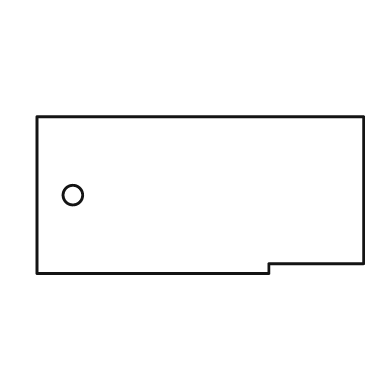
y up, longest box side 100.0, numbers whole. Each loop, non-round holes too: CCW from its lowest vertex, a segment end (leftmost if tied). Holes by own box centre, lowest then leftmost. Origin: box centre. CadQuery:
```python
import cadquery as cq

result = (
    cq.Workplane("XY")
    .moveTo(-50.0, -24.0)
    .lineTo(21.0, -24.0)
    .lineTo(21.0, -21.0)
    .lineTo(50.0, -21.0)
    .lineTo(50.0, 24.0)
    .lineTo(-50.0, 24.0)
    .close()
    .moveTo(-39.0, 0.0)
    .circle(3.0)
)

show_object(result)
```